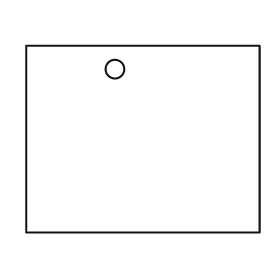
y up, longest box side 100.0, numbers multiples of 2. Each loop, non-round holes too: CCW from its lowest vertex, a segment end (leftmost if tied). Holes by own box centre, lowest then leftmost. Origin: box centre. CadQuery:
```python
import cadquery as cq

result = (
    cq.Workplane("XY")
    .moveTo(-50.0, -40.0)
    .lineTo(50.0, -40.0)
    .lineTo(50.0, 40.0)
    .lineTo(-50.0, 40.0)
    .close()
    .moveTo(-12.0, 30.0)
    .circle(4.0)
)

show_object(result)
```